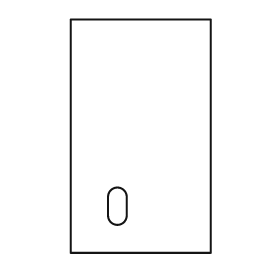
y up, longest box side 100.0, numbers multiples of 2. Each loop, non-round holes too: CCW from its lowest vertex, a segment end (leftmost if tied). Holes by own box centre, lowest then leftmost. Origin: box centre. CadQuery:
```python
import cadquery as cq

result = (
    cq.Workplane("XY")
    .moveTo(-30.0, -50.0)
    .lineTo(30.0, -50.0)
    .lineTo(30.0, 50.0)
    .lineTo(-30.0, 50.0)
    .close()
    .moveTo(-14.0, -34.0)
    .threePointArc((-10.0, -38.0), (-6.0, -34.0))
    .lineTo(-6.0, -26.0)
    .threePointArc((-10.0, -22.0), (-14.0, -26.0))
    .close()
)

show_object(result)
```